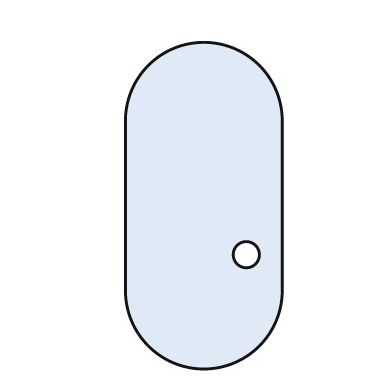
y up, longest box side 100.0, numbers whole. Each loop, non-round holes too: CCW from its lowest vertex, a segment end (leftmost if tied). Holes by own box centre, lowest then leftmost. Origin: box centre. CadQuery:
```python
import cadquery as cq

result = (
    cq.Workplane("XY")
    .moveTo(-24.0, -26.0)
    .threePointArc((0.0, -50.0), (24.0, -26.0))
    .lineTo(24.0, 26.0)
    .threePointArc((0.0, 50.0), (-24.0, 26.0))
    .close()
    .moveTo(13.0, -15.0)
    .circle(4.0)
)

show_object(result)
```